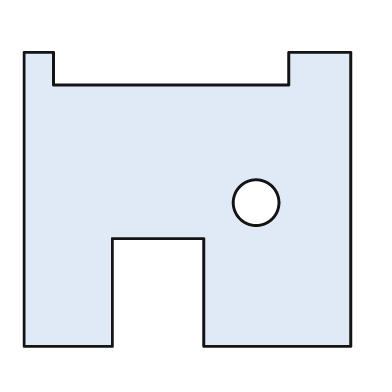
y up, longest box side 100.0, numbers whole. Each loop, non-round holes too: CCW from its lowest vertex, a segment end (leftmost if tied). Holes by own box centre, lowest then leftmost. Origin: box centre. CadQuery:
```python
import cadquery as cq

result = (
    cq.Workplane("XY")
    .moveTo(-50.0, -45.0)
    .lineTo(-23.0, -45.0)
    .lineTo(-23.0, -12.0)
    .lineTo(5.0, -12.0)
    .lineTo(5.0, -45.0)
    .lineTo(50.0, -45.0)
    .lineTo(50.0, 45.0)
    .lineTo(31.0, 45.0)
    .lineTo(31.0, 35.0)
    .lineTo(-41.0, 35.0)
    .lineTo(-41.0, 45.0)
    .lineTo(-50.0, 45.0)
    .close()
    .moveTo(21.0, -1.0)
    .circle(7.0)
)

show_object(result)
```